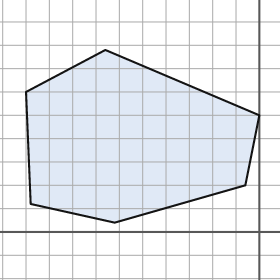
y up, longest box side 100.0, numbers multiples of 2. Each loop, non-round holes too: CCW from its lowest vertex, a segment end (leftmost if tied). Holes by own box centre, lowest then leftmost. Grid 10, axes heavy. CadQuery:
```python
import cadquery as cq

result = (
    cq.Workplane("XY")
    .moveTo(-62.0, 4.0)
    .lineTo(-6.0, 20.0)
    .lineTo(0.0, 50.0)
    .lineTo(-66.0, 78.0)
    .lineTo(-100.0, 60.0)
    .lineTo(-98.0, 12.0)
    .close()
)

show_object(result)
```